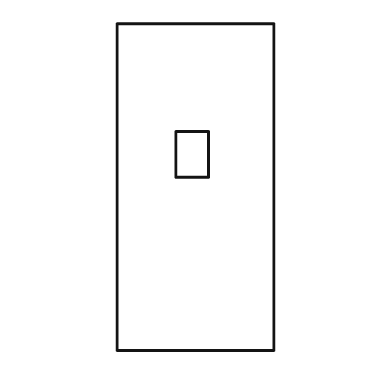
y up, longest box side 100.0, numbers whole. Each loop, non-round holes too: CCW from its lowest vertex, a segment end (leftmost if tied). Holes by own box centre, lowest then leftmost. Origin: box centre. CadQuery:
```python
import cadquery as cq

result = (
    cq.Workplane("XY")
    .moveTo(-24.0, -50.0)
    .lineTo(24.0, -50.0)
    .lineTo(24.0, 50.0)
    .lineTo(-24.0, 50.0)
    .close()
    .moveTo(-6.0, 3.0)
    .lineTo(4.0, 3.0)
    .lineTo(4.0, 17.0)
    .lineTo(-6.0, 17.0)
    .close()
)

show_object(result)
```